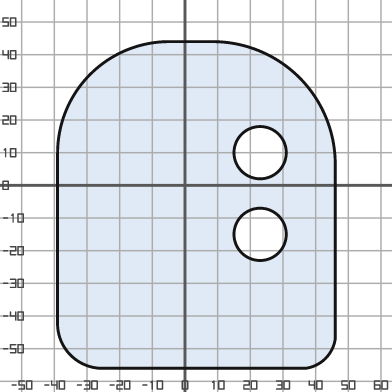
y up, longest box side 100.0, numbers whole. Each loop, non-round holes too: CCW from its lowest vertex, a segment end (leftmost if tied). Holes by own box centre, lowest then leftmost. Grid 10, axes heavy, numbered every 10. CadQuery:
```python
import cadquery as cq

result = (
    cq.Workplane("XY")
    .moveTo(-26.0, -56.0)
    .lineTo(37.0, -56.0)
    .threePointArc((43.0, -53.0), (46.0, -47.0))
    .lineTo(46.0, 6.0)
    .threePointArc((35.0, 33.0), (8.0, 44.0))
    .lineTo(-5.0, 44.0)
    .threePointArc((-29.0, 34.0), (-39.0, 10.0))
    .lineTo(-39.0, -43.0)
    .threePointArc((-35.0, -52.0), (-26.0, -56.0))
    .close()
    .moveTo(23.0, -15.0)
    .circle(8.0)
    .moveTo(23.0, 10.0)
    .circle(8.0)
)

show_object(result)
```